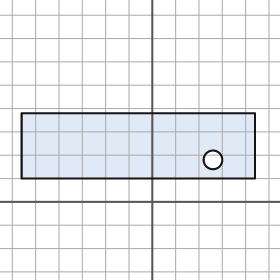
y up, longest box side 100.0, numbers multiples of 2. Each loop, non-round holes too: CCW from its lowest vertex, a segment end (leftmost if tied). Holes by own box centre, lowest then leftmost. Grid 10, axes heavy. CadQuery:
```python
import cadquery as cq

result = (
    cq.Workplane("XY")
    .moveTo(-56.0, 10.0)
    .lineTo(44.0, 10.0)
    .lineTo(44.0, 38.0)
    .lineTo(-56.0, 38.0)
    .close()
    .moveTo(26.0, 18.0)
    .circle(4.0)
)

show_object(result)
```